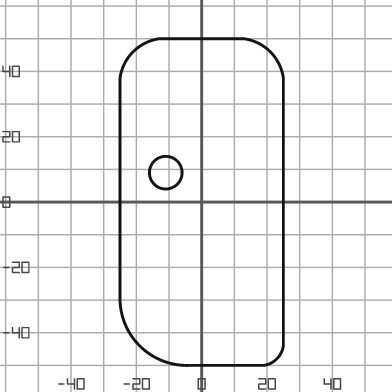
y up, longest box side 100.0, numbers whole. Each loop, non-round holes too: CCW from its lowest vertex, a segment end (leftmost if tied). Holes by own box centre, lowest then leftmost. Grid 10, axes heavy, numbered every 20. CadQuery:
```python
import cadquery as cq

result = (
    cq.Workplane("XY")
    .moveTo(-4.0, -50.0)
    .lineTo(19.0, -50.0)
    .threePointArc((23.0, -48.0), (25.0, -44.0))
    .lineTo(25.0, 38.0)
    .threePointArc((21.0, 46.0), (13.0, 50.0))
    .lineTo(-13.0, 50.0)
    .threePointArc((-21.0, 46.0), (-25.0, 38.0))
    .lineTo(-25.0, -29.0)
    .threePointArc((-19.0, -44.0), (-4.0, -50.0))
    .close()
    .moveTo(-11.0, 9.0)
    .circle(5.0)
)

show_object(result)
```